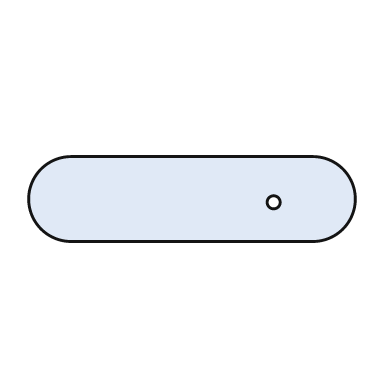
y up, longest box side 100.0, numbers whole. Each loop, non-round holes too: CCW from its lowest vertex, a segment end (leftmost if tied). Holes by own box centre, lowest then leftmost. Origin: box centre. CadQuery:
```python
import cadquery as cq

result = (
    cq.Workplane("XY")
    .moveTo(-37.0, -13.0)
    .lineTo(37.0, -13.0)
    .threePointArc((50.0, 0.0), (37.0, 13.0))
    .lineTo(-37.0, 13.0)
    .threePointArc((-50.0, 0.0), (-37.0, -13.0))
    .close()
    .moveTo(25.0, -1.0)
    .circle(2.0)
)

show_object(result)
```